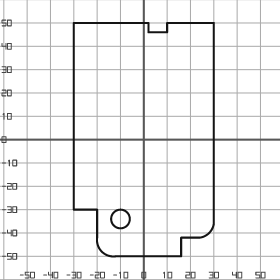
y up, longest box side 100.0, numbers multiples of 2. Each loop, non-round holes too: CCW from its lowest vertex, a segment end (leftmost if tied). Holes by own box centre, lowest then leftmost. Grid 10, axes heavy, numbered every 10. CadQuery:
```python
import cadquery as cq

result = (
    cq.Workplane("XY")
    .moveTo(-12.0, -50.0)
    .lineTo(16.0, -50.0)
    .lineTo(16.0, -42.0)
    .lineTo(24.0, -42.0)
    .threePointArc((28.0, -40.0), (30.0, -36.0))
    .lineTo(30.0, 50.0)
    .lineTo(10.0, 50.0)
    .lineTo(10.0, 46.0)
    .lineTo(2.0, 46.0)
    .lineTo(2.0, 50.0)
    .lineTo(-30.0, 50.0)
    .lineTo(-30.0, -30.0)
    .lineTo(-20.0, -30.0)
    .lineTo(-20.0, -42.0)
    .threePointArc((-18.0, -48.0), (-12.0, -50.0))
    .close()
    .moveTo(-10.0, -34.0)
    .circle(4.0)
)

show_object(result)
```